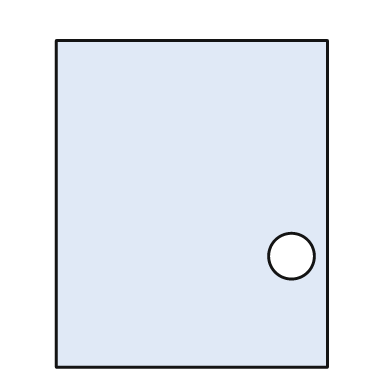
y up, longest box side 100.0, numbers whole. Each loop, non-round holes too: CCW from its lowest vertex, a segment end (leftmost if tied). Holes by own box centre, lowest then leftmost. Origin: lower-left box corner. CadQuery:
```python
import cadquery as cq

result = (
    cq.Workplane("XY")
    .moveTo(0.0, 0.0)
    .lineTo(83.0, 0.0)
    .lineTo(83.0, 100.0)
    .lineTo(0.0, 100.0)
    .close()
    .moveTo(72.0, 34.0)
    .circle(7.0)
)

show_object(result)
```